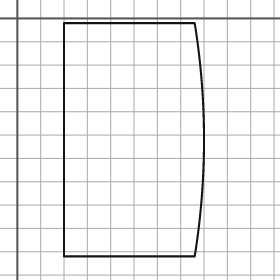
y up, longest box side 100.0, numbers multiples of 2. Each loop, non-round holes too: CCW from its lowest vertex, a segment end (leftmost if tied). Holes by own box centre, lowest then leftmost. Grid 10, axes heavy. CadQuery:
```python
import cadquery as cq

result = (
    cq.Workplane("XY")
    .moveTo(20.0, -102.0)
    .lineTo(76.0, -102.0)
    .threePointArc((80.0, -52.0), (76.0, -2.0))
    .lineTo(20.0, -2.0)
    .close()
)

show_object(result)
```